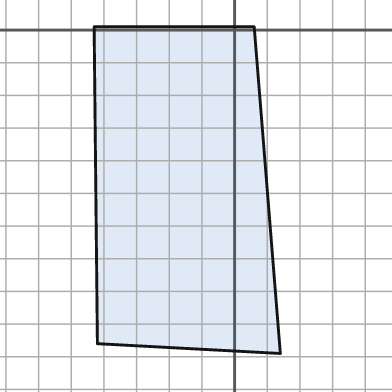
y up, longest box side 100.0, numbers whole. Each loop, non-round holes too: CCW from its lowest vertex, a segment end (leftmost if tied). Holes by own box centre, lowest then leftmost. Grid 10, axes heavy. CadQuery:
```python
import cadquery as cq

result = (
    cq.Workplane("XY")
    .moveTo(14.0, -99.0)
    .lineTo(6.0, 1.0)
    .lineTo(-43.0, 1.0)
    .lineTo(-42.0, -96.0)
    .close()
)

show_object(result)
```